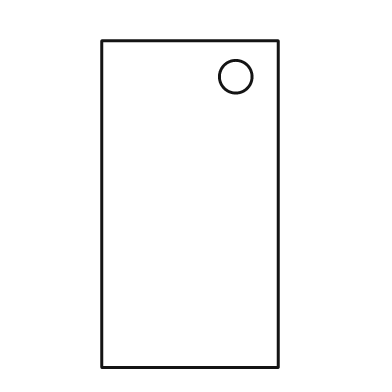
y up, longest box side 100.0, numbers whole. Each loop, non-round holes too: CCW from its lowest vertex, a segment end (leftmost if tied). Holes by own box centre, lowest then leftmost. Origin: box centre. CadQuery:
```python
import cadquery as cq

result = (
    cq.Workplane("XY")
    .moveTo(-27.0, -50.0)
    .lineTo(27.0, -50.0)
    .lineTo(27.0, 50.0)
    .lineTo(-27.0, 50.0)
    .close()
    .moveTo(14.0, 39.0)
    .circle(5.0)
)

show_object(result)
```